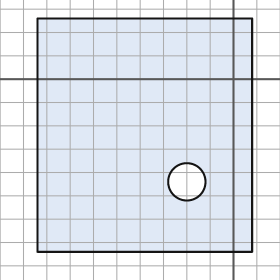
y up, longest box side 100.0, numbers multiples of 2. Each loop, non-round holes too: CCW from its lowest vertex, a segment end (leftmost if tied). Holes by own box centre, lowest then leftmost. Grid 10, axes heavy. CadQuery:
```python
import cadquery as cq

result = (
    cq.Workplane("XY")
    .moveTo(-84.0, -74.0)
    .lineTo(8.0, -74.0)
    .lineTo(8.0, 26.0)
    .lineTo(-84.0, 26.0)
    .close()
    .moveTo(-20.0, -44.0)
    .circle(8.0)
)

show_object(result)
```